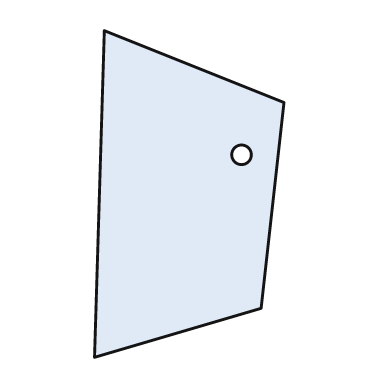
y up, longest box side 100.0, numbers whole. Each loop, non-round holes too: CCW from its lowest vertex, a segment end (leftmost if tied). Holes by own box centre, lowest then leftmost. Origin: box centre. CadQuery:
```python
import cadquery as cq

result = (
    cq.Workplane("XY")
    .moveTo(-29.0, -50.0)
    .lineTo(22.0, -35.0)
    .lineTo(29.0, 28.0)
    .lineTo(-26.0, 50.0)
    .close()
    .moveTo(16.0, 12.0)
    .circle(3.0)
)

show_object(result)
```